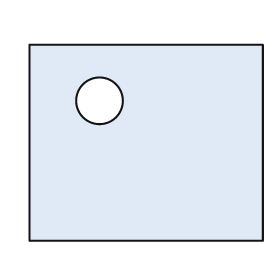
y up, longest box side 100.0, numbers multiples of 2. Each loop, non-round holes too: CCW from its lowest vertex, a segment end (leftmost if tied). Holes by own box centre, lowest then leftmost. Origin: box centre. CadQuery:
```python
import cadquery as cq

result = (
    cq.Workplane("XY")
    .moveTo(-50.0, -42.0)
    .lineTo(50.0, -42.0)
    .lineTo(50.0, 42.0)
    .lineTo(-50.0, 42.0)
    .close()
    .moveTo(-20.0, 18.0)
    .circle(10.0)
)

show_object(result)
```